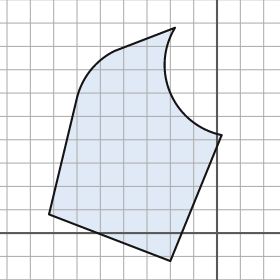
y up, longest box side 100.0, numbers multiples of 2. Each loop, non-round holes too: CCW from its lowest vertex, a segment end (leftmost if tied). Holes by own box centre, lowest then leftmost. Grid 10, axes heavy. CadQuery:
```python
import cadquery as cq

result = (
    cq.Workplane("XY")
    .moveTo(-20.0, -12.0)
    .lineTo(2.0, 42.0)
    .threePointArc((-20.0, 60.0), (-18.0, 88.0))
    .lineTo(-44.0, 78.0)
    .threePointArc((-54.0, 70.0), (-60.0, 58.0))
    .lineTo(-72.0, 8.0)
    .close()
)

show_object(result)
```